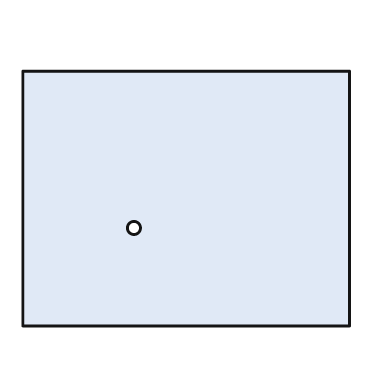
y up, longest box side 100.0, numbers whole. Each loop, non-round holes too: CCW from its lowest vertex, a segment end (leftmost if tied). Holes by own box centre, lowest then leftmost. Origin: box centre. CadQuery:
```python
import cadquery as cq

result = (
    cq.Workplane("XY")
    .moveTo(-50.0, -39.0)
    .lineTo(50.0, -39.0)
    .lineTo(50.0, 39.0)
    .lineTo(-50.0, 39.0)
    .close()
    .moveTo(-16.0, -9.0)
    .circle(2.0)
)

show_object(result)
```